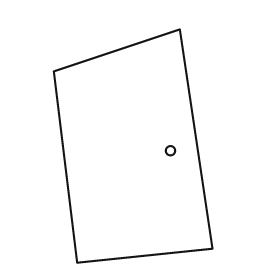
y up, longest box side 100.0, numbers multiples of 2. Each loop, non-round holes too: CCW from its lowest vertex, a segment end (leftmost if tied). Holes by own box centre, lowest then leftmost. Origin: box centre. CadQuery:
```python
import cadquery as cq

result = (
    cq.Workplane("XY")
    .moveTo(-24.0, -50.0)
    .lineTo(34.0, -44.0)
    .lineTo(20.0, 50.0)
    .lineTo(-34.0, 32.0)
    .close()
    .moveTo(16.0, -2.0)
    .circle(2.0)
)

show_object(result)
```